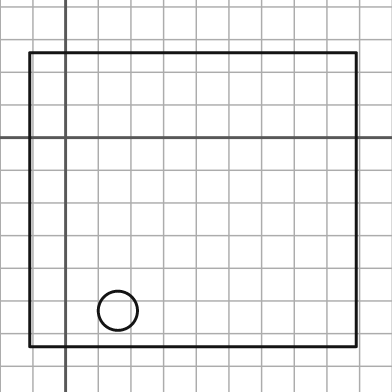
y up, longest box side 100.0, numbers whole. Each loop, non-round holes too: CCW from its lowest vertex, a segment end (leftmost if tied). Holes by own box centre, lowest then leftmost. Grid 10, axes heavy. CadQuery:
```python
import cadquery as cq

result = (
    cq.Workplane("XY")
    .moveTo(-11.0, -64.0)
    .lineTo(89.0, -64.0)
    .lineTo(89.0, 26.0)
    .lineTo(-11.0, 26.0)
    .close()
    .moveTo(16.0, -53.0)
    .circle(6.0)
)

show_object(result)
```